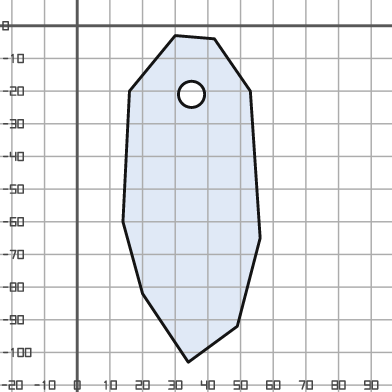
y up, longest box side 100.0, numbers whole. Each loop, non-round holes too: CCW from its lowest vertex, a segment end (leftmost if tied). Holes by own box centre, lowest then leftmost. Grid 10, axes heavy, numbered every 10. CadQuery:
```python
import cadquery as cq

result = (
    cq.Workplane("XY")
    .moveTo(34.0, -103.0)
    .lineTo(49.0, -92.0)
    .lineTo(56.0, -65.0)
    .lineTo(53.0, -20.0)
    .lineTo(42.0, -4.0)
    .lineTo(30.0, -3.0)
    .lineTo(16.0, -20.0)
    .lineTo(14.0, -60.0)
    .lineTo(20.0, -82.0)
    .close()
    .moveTo(35.0, -21.0)
    .circle(4.0)
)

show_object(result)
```